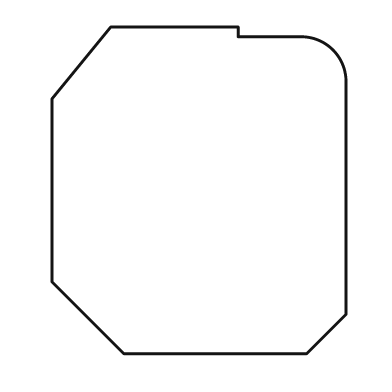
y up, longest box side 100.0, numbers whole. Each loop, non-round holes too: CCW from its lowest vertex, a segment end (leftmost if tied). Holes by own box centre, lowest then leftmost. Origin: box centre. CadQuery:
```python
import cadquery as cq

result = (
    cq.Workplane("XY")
    .moveTo(-23.0, -50.0)
    .lineTo(33.0, -50.0)
    .lineTo(45.0, -38.0)
    .lineTo(45.0, 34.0)
    .threePointArc((41.0, 43.0), (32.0, 47.0))
    .lineTo(12.0, 47.0)
    .lineTo(12.0, 50.0)
    .lineTo(-27.0, 50.0)
    .lineTo(-45.0, 28.0)
    .lineTo(-45.0, -28.0)
    .close()
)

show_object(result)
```